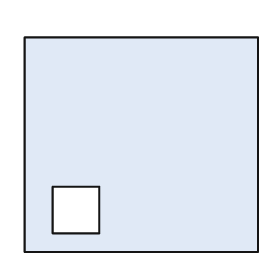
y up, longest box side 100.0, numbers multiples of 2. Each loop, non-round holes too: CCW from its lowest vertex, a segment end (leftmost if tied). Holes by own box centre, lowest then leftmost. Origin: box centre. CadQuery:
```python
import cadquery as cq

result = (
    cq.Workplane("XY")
    .moveTo(-50.0, -46.0)
    .lineTo(50.0, -46.0)
    .lineTo(50.0, 46.0)
    .lineTo(-50.0, 46.0)
    .close()
    .moveTo(-38.0, -38.0)
    .lineTo(-18.0, -38.0)
    .lineTo(-18.0, -18.0)
    .lineTo(-38.0, -18.0)
    .close()
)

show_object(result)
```